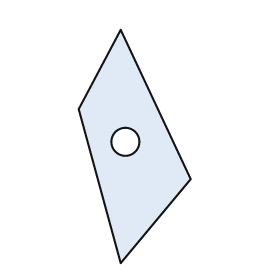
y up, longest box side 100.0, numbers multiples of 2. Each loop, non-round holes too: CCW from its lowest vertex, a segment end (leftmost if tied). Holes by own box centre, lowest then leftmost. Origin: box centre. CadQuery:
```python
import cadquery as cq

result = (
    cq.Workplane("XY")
    .moveTo(-6.0, -50.0)
    .lineTo(24.0, -14.0)
    .lineTo(-6.0, 50.0)
    .lineTo(-24.0, 16.0)
    .close()
    .moveTo(-4.0, 2.0)
    .circle(6.0)
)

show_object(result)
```